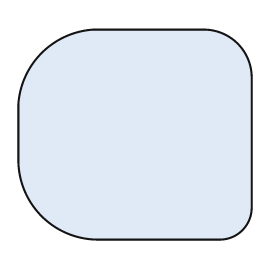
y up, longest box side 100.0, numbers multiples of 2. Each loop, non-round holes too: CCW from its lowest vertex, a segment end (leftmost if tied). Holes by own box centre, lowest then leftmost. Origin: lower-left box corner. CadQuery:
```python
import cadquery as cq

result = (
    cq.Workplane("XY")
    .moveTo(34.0, 0.0)
    .lineTo(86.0, 0.0)
    .threePointArc((96.0, 4.0), (100.0, 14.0))
    .lineTo(100.0, 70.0)
    .threePointArc((94.0, 84.0), (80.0, 90.0))
    .lineTo(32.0, 90.0)
    .threePointArc((10.0, 80.0), (0.0, 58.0))
    .lineTo(0.0, 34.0)
    .threePointArc((10.0, 10.0), (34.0, 0.0))
    .close()
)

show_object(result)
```